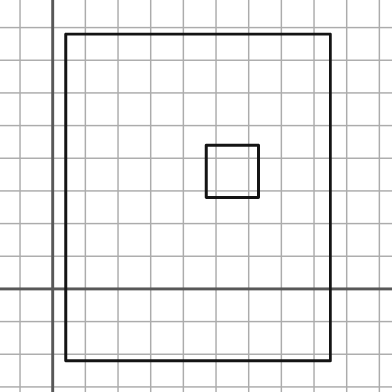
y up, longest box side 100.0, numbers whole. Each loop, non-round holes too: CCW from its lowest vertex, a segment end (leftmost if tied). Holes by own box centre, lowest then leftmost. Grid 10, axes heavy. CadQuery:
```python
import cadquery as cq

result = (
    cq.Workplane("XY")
    .moveTo(4.0, -22.0)
    .lineTo(85.0, -22.0)
    .lineTo(85.0, 78.0)
    .lineTo(4.0, 78.0)
    .close()
    .moveTo(47.0, 28.0)
    .lineTo(63.0, 28.0)
    .lineTo(63.0, 44.0)
    .lineTo(47.0, 44.0)
    .close()
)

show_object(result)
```